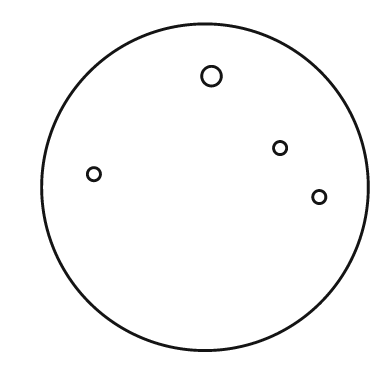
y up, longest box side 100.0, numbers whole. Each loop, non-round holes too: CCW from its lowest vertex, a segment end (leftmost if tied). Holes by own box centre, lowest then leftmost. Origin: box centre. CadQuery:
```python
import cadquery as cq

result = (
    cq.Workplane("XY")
    .moveTo(0.0, 0.0)
    .circle(50.0)
    .moveTo(35.0, -3.0)
    .circle(2.0)
    .moveTo(-34.0, 4.0)
    .circle(2.0)
    .moveTo(23.0, 12.0)
    .circle(2.0)
    .moveTo(2.0, 34.0)
    .circle(3.0)
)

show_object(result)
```